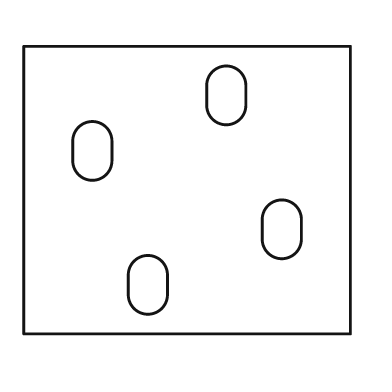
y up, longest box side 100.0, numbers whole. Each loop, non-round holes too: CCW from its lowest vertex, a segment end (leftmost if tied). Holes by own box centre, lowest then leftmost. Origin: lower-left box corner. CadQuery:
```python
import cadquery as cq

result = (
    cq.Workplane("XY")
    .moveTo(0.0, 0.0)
    .lineTo(100.0, 0.0)
    .lineTo(100.0, 88.0)
    .lineTo(0.0, 88.0)
    .close()
    .moveTo(32.0, 12.0)
    .threePointArc((38.0, 6.0), (44.0, 12.0))
    .lineTo(44.0, 18.0)
    .threePointArc((38.0, 24.0), (32.0, 18.0))
    .close()
    .moveTo(73.0, 29.0)
    .threePointArc((79.0, 23.0), (85.0, 29.0))
    .lineTo(85.0, 35.0)
    .threePointArc((79.0, 41.0), (73.0, 35.0))
    .close()
    .moveTo(15.0, 53.0)
    .threePointArc((21.0, 47.0), (27.0, 53.0))
    .lineTo(27.0, 59.0)
    .threePointArc((21.0, 65.0), (15.0, 59.0))
    .close()
    .moveTo(56.0, 70.0)
    .threePointArc((62.0, 64.0), (68.0, 70.0))
    .lineTo(68.0, 76.0)
    .threePointArc((62.0, 82.0), (56.0, 76.0))
    .close()
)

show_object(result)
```